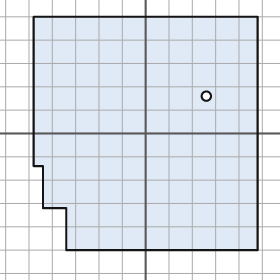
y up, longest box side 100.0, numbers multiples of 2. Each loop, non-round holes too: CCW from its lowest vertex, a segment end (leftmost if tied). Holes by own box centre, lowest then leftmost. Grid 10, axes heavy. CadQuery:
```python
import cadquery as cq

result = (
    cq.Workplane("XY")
    .moveTo(-34.0, -50.0)
    .lineTo(48.0, -50.0)
    .lineTo(48.0, 50.0)
    .lineTo(-48.0, 50.0)
    .lineTo(-48.0, -14.0)
    .lineTo(-44.0, -14.0)
    .lineTo(-44.0, -32.0)
    .lineTo(-34.0, -32.0)
    .close()
    .moveTo(26.0, 16.0)
    .circle(2.0)
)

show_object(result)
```